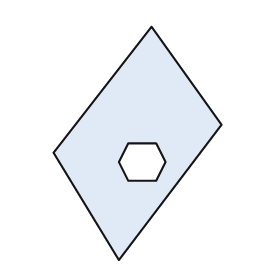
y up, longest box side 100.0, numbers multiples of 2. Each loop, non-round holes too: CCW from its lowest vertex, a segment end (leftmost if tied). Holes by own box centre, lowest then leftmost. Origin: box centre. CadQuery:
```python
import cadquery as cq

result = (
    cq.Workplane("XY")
    .moveTo(-8.0, -50.0)
    .lineTo(36.0, 8.0)
    .lineTo(6.0, 50.0)
    .lineTo(-36.0, -4.0)
    .close()
    .moveTo(-4.0, -16.0)
    .lineTo(8.0, -16.0)
    .lineTo(12.0, -8.0)
    .lineTo(8.0, 0.0)
    .lineTo(-4.0, 0.0)
    .lineTo(-8.0, -8.0)
    .close()
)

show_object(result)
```